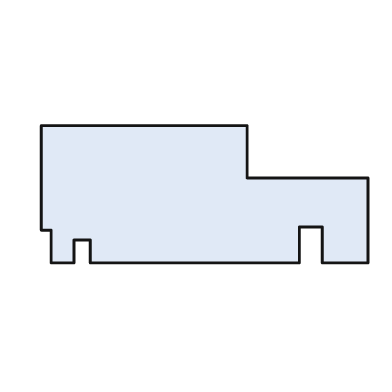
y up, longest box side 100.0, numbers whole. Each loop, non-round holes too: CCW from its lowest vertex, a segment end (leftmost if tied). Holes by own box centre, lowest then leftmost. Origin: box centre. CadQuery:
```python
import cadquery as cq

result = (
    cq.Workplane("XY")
    .moveTo(-47.0, -21.0)
    .lineTo(-40.0, -21.0)
    .lineTo(-40.0, -14.0)
    .lineTo(-35.0, -14.0)
    .lineTo(-35.0, -21.0)
    .lineTo(29.0, -21.0)
    .lineTo(29.0, -10.0)
    .lineTo(36.0, -10.0)
    .lineTo(36.0, -21.0)
    .lineTo(50.0, -21.0)
    .lineTo(50.0, 5.0)
    .lineTo(13.0, 5.0)
    .lineTo(13.0, 21.0)
    .lineTo(-50.0, 21.0)
    .lineTo(-50.0, -11.0)
    .lineTo(-47.0, -11.0)
    .close()
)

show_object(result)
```